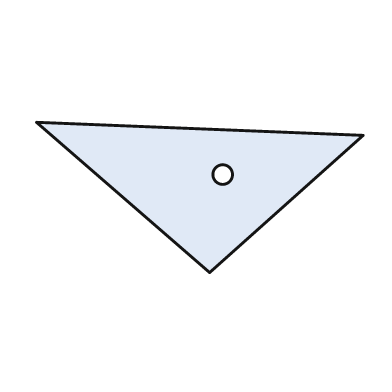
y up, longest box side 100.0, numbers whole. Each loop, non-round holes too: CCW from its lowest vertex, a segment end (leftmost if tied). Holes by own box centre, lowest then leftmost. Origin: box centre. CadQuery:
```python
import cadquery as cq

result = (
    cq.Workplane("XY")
    .moveTo(3.0, -23.0)
    .lineTo(50.0, 19.0)
    .lineTo(-50.0, 23.0)
    .close()
    .moveTo(7.0, 7.0)
    .circle(3.0)
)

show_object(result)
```